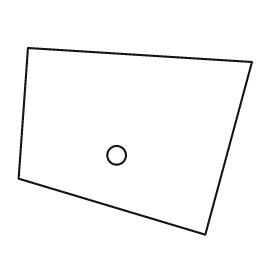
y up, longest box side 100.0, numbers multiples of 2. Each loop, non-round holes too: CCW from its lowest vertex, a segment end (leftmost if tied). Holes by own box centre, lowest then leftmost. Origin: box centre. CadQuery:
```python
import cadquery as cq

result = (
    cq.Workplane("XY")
    .moveTo(30.0, -40.0)
    .lineTo(50.0, 34.0)
    .lineTo(-46.0, 40.0)
    .lineTo(-50.0, -16.0)
    .close()
    .moveTo(-8.0, -6.0)
    .circle(4.0)
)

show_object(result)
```